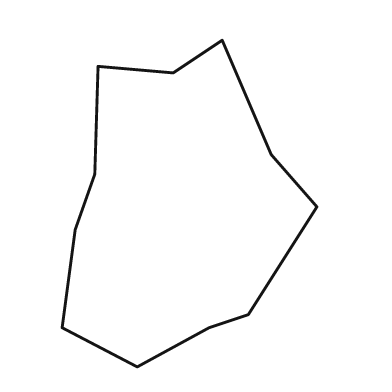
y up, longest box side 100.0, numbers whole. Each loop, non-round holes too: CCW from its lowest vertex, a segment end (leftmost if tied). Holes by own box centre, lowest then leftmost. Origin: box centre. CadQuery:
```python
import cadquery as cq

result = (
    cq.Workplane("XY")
    .moveTo(-16.0, -50.0)
    .lineTo(6.0, -38.0)
    .lineTo(18.0, -34.0)
    .lineTo(39.0, -1.0)
    .lineTo(25.0, 15.0)
    .lineTo(10.0, 50.0)
    .lineTo(-5.0, 40.0)
    .lineTo(-28.0, 42.0)
    .lineTo(-29.0, 9.0)
    .lineTo(-35.0, -8.0)
    .lineTo(-39.0, -38.0)
    .close()
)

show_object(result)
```